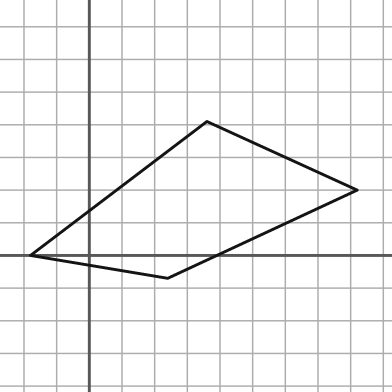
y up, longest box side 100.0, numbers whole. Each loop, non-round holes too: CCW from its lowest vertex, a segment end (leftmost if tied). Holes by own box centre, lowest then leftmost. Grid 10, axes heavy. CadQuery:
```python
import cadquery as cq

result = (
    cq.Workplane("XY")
    .moveTo(24.0, -7.0)
    .lineTo(82.0, 20.0)
    .lineTo(36.0, 41.0)
    .lineTo(-18.0, 0.0)
    .close()
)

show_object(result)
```